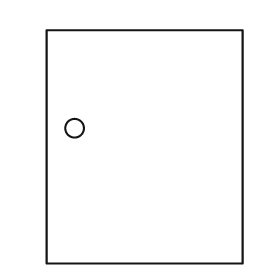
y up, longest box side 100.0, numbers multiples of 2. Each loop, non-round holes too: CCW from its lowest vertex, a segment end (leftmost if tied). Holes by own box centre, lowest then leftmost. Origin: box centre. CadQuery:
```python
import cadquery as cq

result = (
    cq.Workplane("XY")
    .moveTo(-42.0, -50.0)
    .lineTo(42.0, -50.0)
    .lineTo(42.0, 50.0)
    .lineTo(-42.0, 50.0)
    .close()
    .moveTo(-30.0, 8.0)
    .circle(4.0)
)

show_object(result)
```